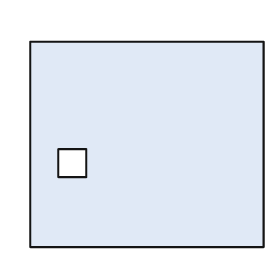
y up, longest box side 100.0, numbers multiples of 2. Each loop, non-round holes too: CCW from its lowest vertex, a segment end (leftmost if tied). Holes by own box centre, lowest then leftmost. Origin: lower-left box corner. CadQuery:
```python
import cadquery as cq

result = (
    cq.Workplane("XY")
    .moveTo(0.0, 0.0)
    .lineTo(100.0, 0.0)
    .lineTo(100.0, 88.0)
    .lineTo(0.0, 88.0)
    .close()
    .moveTo(12.0, 30.0)
    .lineTo(24.0, 30.0)
    .lineTo(24.0, 42.0)
    .lineTo(12.0, 42.0)
    .close()
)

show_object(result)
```